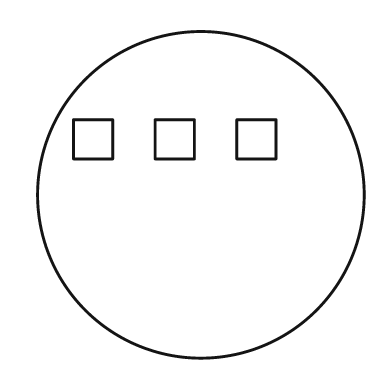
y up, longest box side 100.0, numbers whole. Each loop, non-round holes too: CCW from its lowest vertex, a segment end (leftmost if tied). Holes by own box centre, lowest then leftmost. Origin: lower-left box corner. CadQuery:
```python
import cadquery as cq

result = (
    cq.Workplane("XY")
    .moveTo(50.0, 50.0)
    .circle(50.0)
    .moveTo(11.0, 61.0)
    .lineTo(23.0, 61.0)
    .lineTo(23.0, 73.0)
    .lineTo(11.0, 73.0)
    .close()
    .moveTo(36.0, 61.0)
    .lineTo(48.0, 61.0)
    .lineTo(48.0, 73.0)
    .lineTo(36.0, 73.0)
    .close()
    .moveTo(61.0, 61.0)
    .lineTo(73.0, 61.0)
    .lineTo(73.0, 73.0)
    .lineTo(61.0, 73.0)
    .close()
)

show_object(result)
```